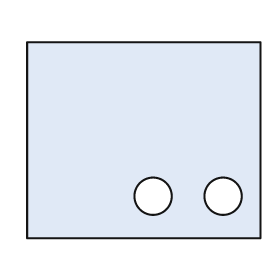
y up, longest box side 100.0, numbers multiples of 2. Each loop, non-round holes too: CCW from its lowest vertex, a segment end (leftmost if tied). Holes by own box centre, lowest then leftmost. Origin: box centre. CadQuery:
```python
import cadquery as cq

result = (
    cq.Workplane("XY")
    .moveTo(-50.0, -42.0)
    .lineTo(50.0, -42.0)
    .lineTo(50.0, 42.0)
    .lineTo(-50.0, 42.0)
    .close()
    .moveTo(4.0, -24.0)
    .circle(8.0)
    .moveTo(34.0, -24.0)
    .circle(8.0)
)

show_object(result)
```